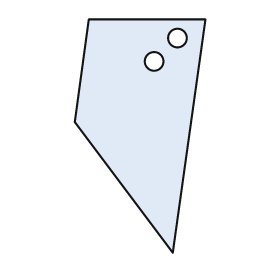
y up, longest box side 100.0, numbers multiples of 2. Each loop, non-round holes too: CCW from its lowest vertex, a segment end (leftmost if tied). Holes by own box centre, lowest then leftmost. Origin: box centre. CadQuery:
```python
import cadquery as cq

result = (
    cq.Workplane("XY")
    .moveTo(14.0, -50.0)
    .lineTo(28.0, 50.0)
    .lineTo(-22.0, 50.0)
    .lineTo(-28.0, 6.0)
    .close()
    .moveTo(6.0, 32.0)
    .circle(4.0)
    .moveTo(16.0, 42.0)
    .circle(4.0)
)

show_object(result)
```